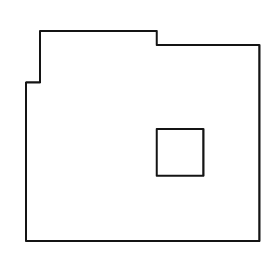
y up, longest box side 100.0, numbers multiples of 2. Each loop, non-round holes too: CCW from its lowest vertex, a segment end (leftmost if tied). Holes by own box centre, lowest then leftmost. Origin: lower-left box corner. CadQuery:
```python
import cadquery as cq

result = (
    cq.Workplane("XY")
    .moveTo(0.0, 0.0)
    .lineTo(100.0, 0.0)
    .lineTo(100.0, 84.0)
    .lineTo(56.0, 84.0)
    .lineTo(56.0, 90.0)
    .lineTo(6.0, 90.0)
    .lineTo(6.0, 68.0)
    .lineTo(0.0, 68.0)
    .close()
    .moveTo(56.0, 28.0)
    .lineTo(76.0, 28.0)
    .lineTo(76.0, 48.0)
    .lineTo(56.0, 48.0)
    .close()
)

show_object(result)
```